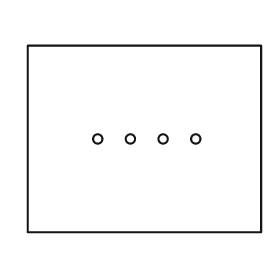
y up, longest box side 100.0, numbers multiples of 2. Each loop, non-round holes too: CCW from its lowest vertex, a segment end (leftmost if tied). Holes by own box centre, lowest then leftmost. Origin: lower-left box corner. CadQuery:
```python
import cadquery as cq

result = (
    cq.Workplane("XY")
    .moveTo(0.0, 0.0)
    .lineTo(100.0, 0.0)
    .lineTo(100.0, 80.0)
    .lineTo(0.0, 80.0)
    .close()
    .moveTo(30.0, 40.0)
    .circle(2.0)
    .moveTo(44.0, 40.0)
    .circle(2.0)
    .moveTo(58.0, 40.0)
    .circle(2.0)
    .moveTo(72.0, 40.0)
    .circle(2.0)
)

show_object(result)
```